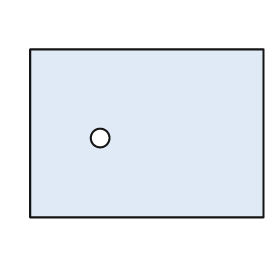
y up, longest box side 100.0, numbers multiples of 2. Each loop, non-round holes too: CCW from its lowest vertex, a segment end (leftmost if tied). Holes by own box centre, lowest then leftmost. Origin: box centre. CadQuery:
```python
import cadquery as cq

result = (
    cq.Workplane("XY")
    .moveTo(-50.0, -36.0)
    .lineTo(50.0, -36.0)
    .lineTo(50.0, 36.0)
    .lineTo(-50.0, 36.0)
    .close()
    .moveTo(-20.0, -2.0)
    .circle(4.0)
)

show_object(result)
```